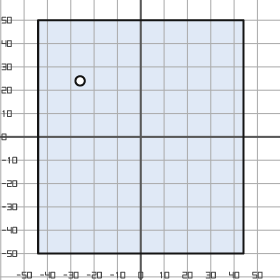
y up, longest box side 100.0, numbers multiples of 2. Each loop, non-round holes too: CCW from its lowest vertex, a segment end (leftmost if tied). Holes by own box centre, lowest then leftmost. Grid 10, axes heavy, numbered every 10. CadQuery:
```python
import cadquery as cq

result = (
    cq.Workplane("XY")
    .moveTo(-44.0, -50.0)
    .lineTo(44.0, -50.0)
    .lineTo(44.0, 50.0)
    .lineTo(-44.0, 50.0)
    .close()
    .moveTo(-26.0, 24.0)
    .circle(2.0)
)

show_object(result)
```